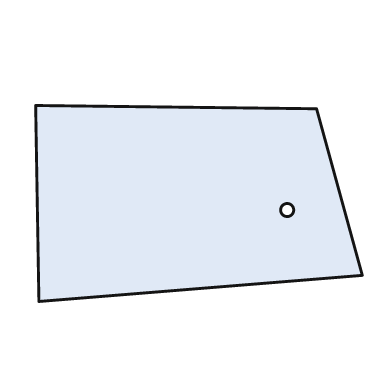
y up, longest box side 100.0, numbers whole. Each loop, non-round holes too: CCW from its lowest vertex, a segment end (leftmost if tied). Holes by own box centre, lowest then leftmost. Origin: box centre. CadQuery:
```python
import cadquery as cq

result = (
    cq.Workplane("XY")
    .moveTo(-49.0, -30.0)
    .lineTo(50.0, -22.0)
    .lineTo(36.0, 29.0)
    .lineTo(-50.0, 30.0)
    .close()
    .moveTo(27.0, -2.0)
    .circle(2.0)
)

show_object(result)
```